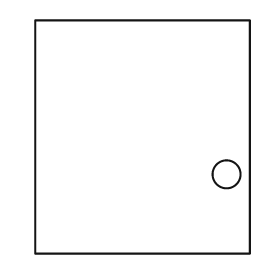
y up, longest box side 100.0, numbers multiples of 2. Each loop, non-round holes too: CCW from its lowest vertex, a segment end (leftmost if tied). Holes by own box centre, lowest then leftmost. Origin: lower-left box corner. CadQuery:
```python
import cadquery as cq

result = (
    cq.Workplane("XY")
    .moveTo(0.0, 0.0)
    .lineTo(92.0, 0.0)
    .lineTo(92.0, 100.0)
    .lineTo(0.0, 100.0)
    .close()
    .moveTo(82.0, 34.0)
    .circle(6.0)
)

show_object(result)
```